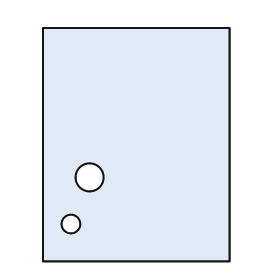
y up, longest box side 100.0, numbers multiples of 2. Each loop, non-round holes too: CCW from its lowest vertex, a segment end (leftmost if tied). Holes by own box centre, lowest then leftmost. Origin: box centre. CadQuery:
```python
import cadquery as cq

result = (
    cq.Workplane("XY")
    .moveTo(-40.0, -50.0)
    .lineTo(40.0, -50.0)
    .lineTo(40.0, 50.0)
    .lineTo(-40.0, 50.0)
    .close()
    .moveTo(-28.0, -34.0)
    .circle(4.0)
    .moveTo(-20.0, -14.0)
    .circle(6.0)
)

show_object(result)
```